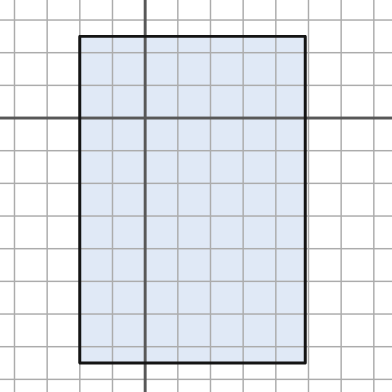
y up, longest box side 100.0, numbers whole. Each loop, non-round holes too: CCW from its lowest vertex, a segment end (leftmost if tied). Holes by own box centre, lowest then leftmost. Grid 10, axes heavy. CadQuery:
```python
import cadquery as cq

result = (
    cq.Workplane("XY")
    .moveTo(-20.0, -75.0)
    .lineTo(49.0, -75.0)
    .lineTo(49.0, 25.0)
    .lineTo(-20.0, 25.0)
    .close()
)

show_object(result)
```